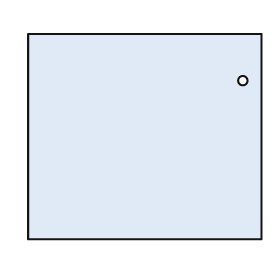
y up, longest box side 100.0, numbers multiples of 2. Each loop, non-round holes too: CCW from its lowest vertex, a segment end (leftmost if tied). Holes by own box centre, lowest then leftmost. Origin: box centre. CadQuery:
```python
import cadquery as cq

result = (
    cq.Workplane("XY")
    .moveTo(-50.0, -44.0)
    .lineTo(50.0, -44.0)
    .lineTo(50.0, 44.0)
    .lineTo(-50.0, 44.0)
    .close()
    .moveTo(42.0, 24.0)
    .circle(2.0)
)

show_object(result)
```